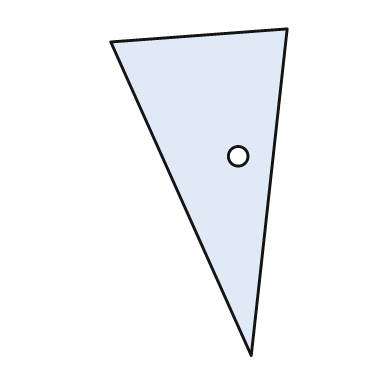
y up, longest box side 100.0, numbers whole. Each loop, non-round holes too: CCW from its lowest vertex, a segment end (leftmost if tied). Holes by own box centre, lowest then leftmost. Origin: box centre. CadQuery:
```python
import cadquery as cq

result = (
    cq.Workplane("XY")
    .moveTo(16.0, -50.0)
    .lineTo(27.0, 50.0)
    .lineTo(-27.0, 46.0)
    .close()
    .moveTo(12.0, 11.0)
    .circle(3.0)
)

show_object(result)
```